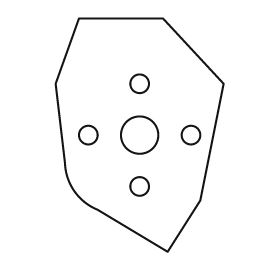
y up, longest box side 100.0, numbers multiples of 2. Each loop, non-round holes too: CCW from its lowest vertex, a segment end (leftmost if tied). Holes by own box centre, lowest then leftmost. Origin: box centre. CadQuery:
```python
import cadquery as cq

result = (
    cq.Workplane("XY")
    .moveTo(12.0, -50.0)
    .lineTo(26.0, -28.0)
    .lineTo(36.0, 22.0)
    .lineTo(10.0, 50.0)
    .lineTo(-26.0, 50.0)
    .lineTo(-36.0, 22.0)
    .lineTo(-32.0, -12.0)
    .threePointArc((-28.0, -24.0), (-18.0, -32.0))
    .close()
    .moveTo(0.0, -22.0)
    .circle(4.0)
    .moveTo(-22.0, 0.0)
    .circle(4.0)
    .moveTo(0.0, 0.0)
    .circle(8.0)
    .moveTo(22.0, 0.0)
    .circle(4.0)
    .moveTo(0.0, 22.0)
    .circle(4.0)
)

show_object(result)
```